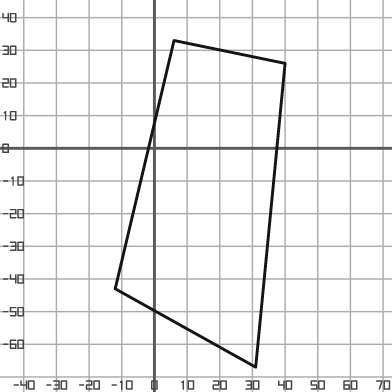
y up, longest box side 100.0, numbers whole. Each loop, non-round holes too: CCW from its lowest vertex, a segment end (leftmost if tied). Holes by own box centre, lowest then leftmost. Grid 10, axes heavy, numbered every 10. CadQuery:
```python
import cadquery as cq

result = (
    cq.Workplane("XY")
    .moveTo(31.0, -67.0)
    .lineTo(40.0, 26.0)
    .lineTo(6.0, 33.0)
    .lineTo(-12.0, -43.0)
    .close()
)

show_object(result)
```